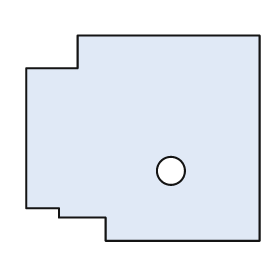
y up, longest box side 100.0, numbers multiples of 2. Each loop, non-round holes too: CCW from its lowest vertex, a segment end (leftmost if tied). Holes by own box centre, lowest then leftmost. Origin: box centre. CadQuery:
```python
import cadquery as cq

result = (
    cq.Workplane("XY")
    .moveTo(-16.0, -44.0)
    .lineTo(50.0, -44.0)
    .lineTo(50.0, 44.0)
    .lineTo(-28.0, 44.0)
    .lineTo(-28.0, 30.0)
    .lineTo(-50.0, 30.0)
    .lineTo(-50.0, -30.0)
    .lineTo(-36.0, -30.0)
    .lineTo(-36.0, -34.0)
    .lineTo(-16.0, -34.0)
    .close()
    .moveTo(12.0, -14.0)
    .circle(6.0)
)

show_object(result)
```